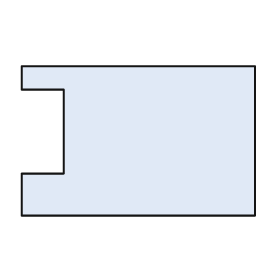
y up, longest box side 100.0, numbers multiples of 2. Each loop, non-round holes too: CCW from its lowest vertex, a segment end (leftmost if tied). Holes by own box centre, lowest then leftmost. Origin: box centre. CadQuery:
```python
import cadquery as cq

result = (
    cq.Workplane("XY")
    .moveTo(-50.0, -32.0)
    .lineTo(50.0, -32.0)
    .lineTo(50.0, 32.0)
    .lineTo(-50.0, 32.0)
    .lineTo(-50.0, 22.0)
    .lineTo(-32.0, 22.0)
    .lineTo(-32.0, -14.0)
    .lineTo(-50.0, -14.0)
    .close()
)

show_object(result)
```